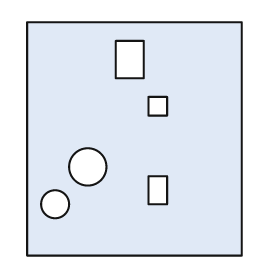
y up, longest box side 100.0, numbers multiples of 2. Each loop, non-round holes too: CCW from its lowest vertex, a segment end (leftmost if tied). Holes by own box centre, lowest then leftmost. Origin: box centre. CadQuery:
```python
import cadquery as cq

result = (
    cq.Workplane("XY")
    .moveTo(-46.0, -50.0)
    .lineTo(46.0, -50.0)
    .lineTo(46.0, 50.0)
    .lineTo(-46.0, 50.0)
    .close()
    .moveTo(-34.0, -28.0)
    .circle(6.0)
    .moveTo(6.0, -28.0)
    .lineTo(14.0, -28.0)
    .lineTo(14.0, -16.0)
    .lineTo(6.0, -16.0)
    .close()
    .moveTo(-20.0, -12.0)
    .circle(8.0)
    .moveTo(6.0, 10.0)
    .lineTo(14.0, 10.0)
    .lineTo(14.0, 18.0)
    .lineTo(6.0, 18.0)
    .close()
    .moveTo(-8.0, 26.0)
    .lineTo(4.0, 26.0)
    .lineTo(4.0, 42.0)
    .lineTo(-8.0, 42.0)
    .close()
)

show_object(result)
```